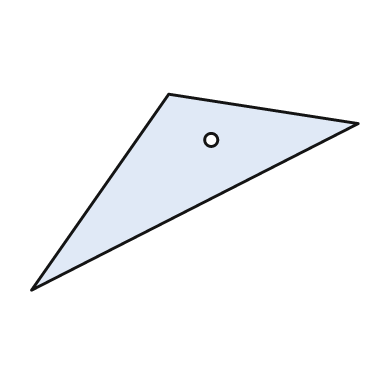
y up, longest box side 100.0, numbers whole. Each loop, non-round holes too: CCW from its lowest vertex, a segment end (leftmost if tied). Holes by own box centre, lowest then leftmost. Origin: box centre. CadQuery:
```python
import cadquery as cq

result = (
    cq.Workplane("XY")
    .moveTo(-50.0, -30.0)
    .lineTo(50.0, 21.0)
    .lineTo(-8.0, 30.0)
    .close()
    .moveTo(5.0, 16.0)
    .circle(2.0)
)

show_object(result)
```